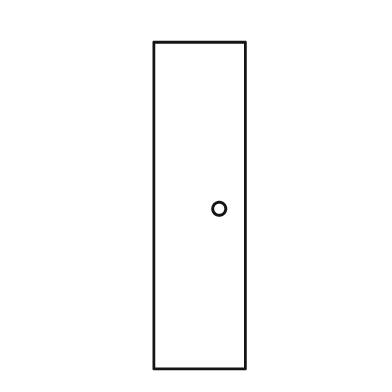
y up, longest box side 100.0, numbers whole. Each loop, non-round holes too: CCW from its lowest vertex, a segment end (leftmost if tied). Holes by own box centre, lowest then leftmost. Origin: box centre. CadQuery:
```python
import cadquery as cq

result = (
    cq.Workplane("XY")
    .moveTo(-14.0, -50.0)
    .lineTo(14.0, -50.0)
    .lineTo(14.0, 50.0)
    .lineTo(-14.0, 50.0)
    .close()
    .moveTo(6.0, -1.0)
    .circle(2.0)
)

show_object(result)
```